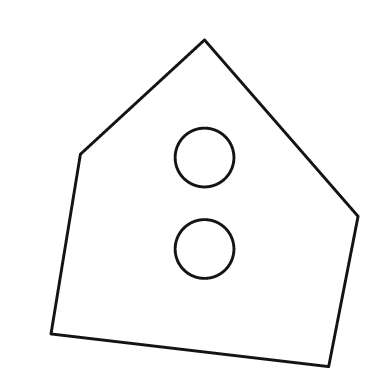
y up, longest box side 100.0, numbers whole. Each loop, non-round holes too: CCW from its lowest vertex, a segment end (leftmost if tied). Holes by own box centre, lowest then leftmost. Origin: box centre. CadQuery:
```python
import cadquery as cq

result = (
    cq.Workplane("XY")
    .moveTo(38.0, -50.0)
    .lineTo(47.0, -4.0)
    .lineTo(0.0, 50.0)
    .lineTo(-38.0, 15.0)
    .lineTo(-47.0, -40.0)
    .close()
    .moveTo(0.0, -14.0)
    .circle(9.0)
    .moveTo(0.0, 14.0)
    .circle(9.0)
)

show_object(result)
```